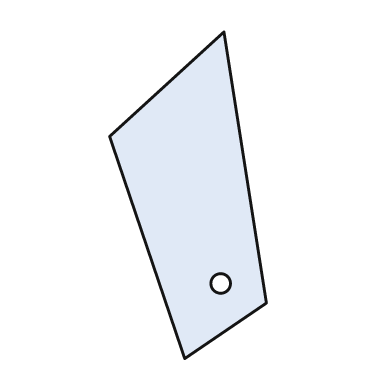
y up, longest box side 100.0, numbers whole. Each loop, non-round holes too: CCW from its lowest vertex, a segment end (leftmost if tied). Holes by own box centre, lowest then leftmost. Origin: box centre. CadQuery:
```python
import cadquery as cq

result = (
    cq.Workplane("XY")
    .moveTo(-1.0, -50.0)
    .lineTo(24.0, -33.0)
    .lineTo(11.0, 50.0)
    .lineTo(-24.0, 18.0)
    .close()
    .moveTo(10.0, -27.0)
    .circle(3.0)
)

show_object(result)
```